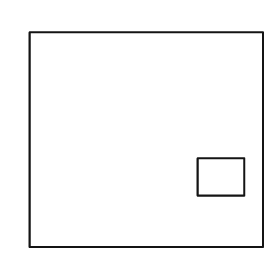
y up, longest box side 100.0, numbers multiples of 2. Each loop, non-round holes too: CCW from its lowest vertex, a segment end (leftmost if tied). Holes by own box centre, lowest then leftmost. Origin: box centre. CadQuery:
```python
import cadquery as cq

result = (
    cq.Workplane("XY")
    .moveTo(-50.0, -46.0)
    .lineTo(50.0, -46.0)
    .lineTo(50.0, 46.0)
    .lineTo(-50.0, 46.0)
    .close()
    .moveTo(22.0, -24.0)
    .lineTo(42.0, -24.0)
    .lineTo(42.0, -8.0)
    .lineTo(22.0, -8.0)
    .close()
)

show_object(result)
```